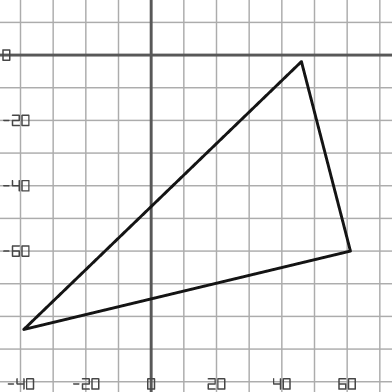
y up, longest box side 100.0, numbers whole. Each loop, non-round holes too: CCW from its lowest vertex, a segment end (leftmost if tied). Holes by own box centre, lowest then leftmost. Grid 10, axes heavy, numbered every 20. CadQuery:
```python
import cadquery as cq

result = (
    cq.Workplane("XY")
    .moveTo(-39.0, -84.0)
    .lineTo(61.0, -60.0)
    .lineTo(46.0, -2.0)
    .close()
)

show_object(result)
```